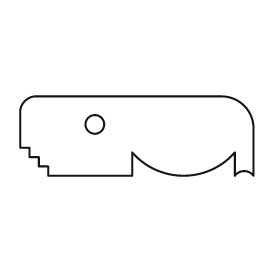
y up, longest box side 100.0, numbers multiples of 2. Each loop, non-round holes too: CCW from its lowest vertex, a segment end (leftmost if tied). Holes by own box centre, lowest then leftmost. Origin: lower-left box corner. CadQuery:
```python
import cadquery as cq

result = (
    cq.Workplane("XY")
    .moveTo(12.0, 0.0)
    .lineTo(48.0, 0.0)
    .lineTo(48.0, 10.0)
    .threePointArc((70.0, 0.0), (92.0, 10.0))
    .lineTo(92.0, 0.0)
    .threePointArc((96.0, 2.0), (100.0, 0.0))
    .lineTo(100.0, 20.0)
    .threePointArc((96.0, 30.0), (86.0, 34.0))
    .lineTo(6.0, 34.0)
    .threePointArc((2.0, 32.0), (0.0, 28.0))
    .lineTo(0.0, 12.0)
    .lineTo(4.0, 12.0)
    .lineTo(4.0, 8.0)
    .lineTo(8.0, 8.0)
    .lineTo(8.0, 4.0)
    .lineTo(12.0, 4.0)
    .close()
    .moveTo(32.0, 22.0)
    .circle(4.0)
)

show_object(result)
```